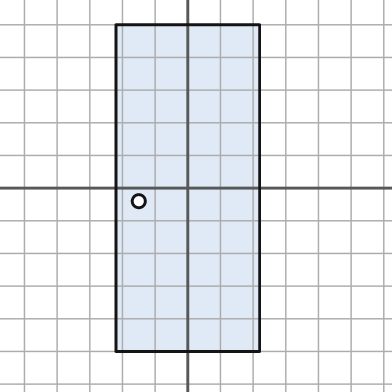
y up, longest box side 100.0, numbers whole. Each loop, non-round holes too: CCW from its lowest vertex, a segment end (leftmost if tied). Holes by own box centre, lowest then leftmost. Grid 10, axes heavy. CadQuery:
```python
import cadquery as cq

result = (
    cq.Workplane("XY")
    .moveTo(-22.0, -50.0)
    .lineTo(22.0, -50.0)
    .lineTo(22.0, 50.0)
    .lineTo(-22.0, 50.0)
    .close()
    .moveTo(-15.0, -4.0)
    .circle(2.0)
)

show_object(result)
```